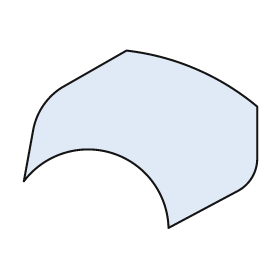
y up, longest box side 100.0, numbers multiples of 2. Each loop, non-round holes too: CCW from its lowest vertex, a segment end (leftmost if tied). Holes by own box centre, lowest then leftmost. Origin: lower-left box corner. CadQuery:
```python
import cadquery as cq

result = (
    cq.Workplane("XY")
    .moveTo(62.0, 0.0)
    .lineTo(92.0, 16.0)
    .threePointArc((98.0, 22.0), (100.0, 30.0))
    .lineTo(100.0, 52.0)
    .threePointArc((74.0, 68.0), (44.0, 76.0))
    .lineTo(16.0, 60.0)
    .threePointArc((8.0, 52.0), (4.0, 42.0))
    .lineTo(0.0, 20.0)
    .threePointArc((38.0, 32.0), (62.0, 0.0))
    .close()
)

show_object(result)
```